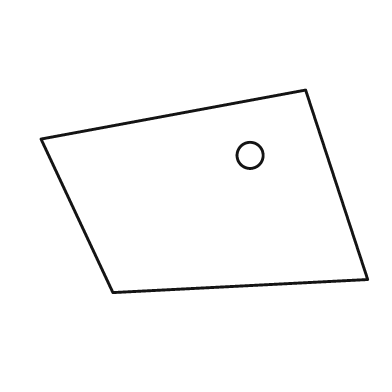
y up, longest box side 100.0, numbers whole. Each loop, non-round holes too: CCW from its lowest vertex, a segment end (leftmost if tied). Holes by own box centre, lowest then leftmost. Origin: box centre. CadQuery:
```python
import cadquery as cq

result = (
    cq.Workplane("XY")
    .moveTo(-28.0, -31.0)
    .lineTo(50.0, -27.0)
    .lineTo(31.0, 31.0)
    .lineTo(-50.0, 16.0)
    .close()
    .moveTo(14.0, 11.0)
    .circle(4.0)
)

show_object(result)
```